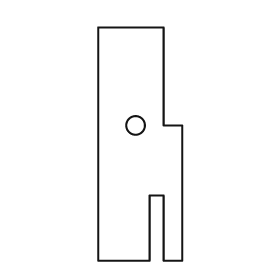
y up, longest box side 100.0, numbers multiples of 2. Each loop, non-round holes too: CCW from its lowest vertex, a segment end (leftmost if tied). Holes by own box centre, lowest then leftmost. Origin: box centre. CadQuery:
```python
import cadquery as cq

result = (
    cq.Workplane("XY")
    .moveTo(-18.0, -50.0)
    .lineTo(4.0, -50.0)
    .lineTo(4.0, -22.0)
    .lineTo(10.0, -22.0)
    .lineTo(10.0, -50.0)
    .lineTo(18.0, -50.0)
    .lineTo(18.0, 8.0)
    .lineTo(10.0, 8.0)
    .lineTo(10.0, 50.0)
    .lineTo(-18.0, 50.0)
    .close()
    .moveTo(-2.0, 8.0)
    .circle(4.0)
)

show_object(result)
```